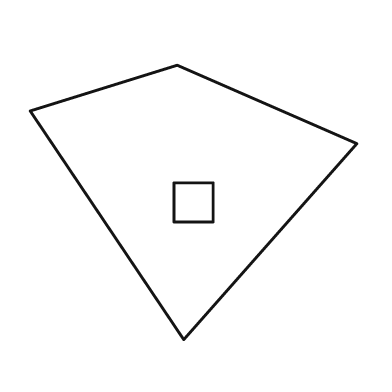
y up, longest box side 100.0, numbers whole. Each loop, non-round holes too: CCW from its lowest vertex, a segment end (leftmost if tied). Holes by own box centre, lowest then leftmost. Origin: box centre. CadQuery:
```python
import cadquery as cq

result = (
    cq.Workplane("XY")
    .moveTo(-3.0, -42.0)
    .lineTo(50.0, 18.0)
    .lineTo(-5.0, 42.0)
    .lineTo(-50.0, 28.0)
    .close()
    .moveTo(-6.0, -6.0)
    .lineTo(6.0, -6.0)
    .lineTo(6.0, 6.0)
    .lineTo(-6.0, 6.0)
    .close()
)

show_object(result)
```